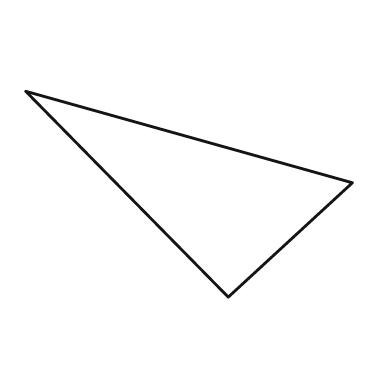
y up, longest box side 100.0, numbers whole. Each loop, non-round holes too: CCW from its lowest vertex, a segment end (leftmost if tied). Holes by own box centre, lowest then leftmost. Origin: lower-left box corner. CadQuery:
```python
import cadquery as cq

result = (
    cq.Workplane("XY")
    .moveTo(62.0, 0.0)
    .lineTo(100.0, 35.0)
    .lineTo(0.0, 63.0)
    .close()
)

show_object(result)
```